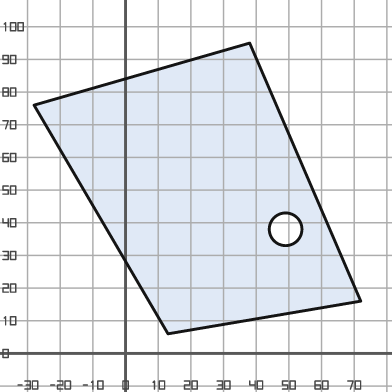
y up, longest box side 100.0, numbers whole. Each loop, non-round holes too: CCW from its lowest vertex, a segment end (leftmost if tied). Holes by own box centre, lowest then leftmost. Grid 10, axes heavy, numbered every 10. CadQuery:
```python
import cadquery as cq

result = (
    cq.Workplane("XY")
    .moveTo(13.0, 6.0)
    .lineTo(72.0, 16.0)
    .lineTo(38.0, 95.0)
    .lineTo(-28.0, 76.0)
    .close()
    .moveTo(49.0, 38.0)
    .circle(5.0)
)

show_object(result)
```